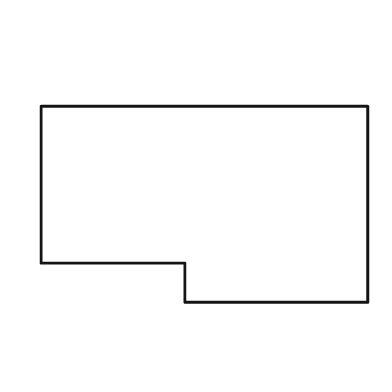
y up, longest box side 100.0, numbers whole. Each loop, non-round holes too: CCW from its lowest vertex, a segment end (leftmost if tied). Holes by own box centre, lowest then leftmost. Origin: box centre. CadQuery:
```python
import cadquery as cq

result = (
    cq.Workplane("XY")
    .moveTo(-6.0, -30.0)
    .lineTo(50.0, -30.0)
    .lineTo(50.0, 30.0)
    .lineTo(-50.0, 30.0)
    .lineTo(-50.0, -18.0)
    .lineTo(-6.0, -18.0)
    .close()
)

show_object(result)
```